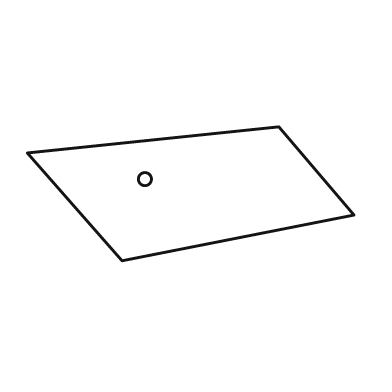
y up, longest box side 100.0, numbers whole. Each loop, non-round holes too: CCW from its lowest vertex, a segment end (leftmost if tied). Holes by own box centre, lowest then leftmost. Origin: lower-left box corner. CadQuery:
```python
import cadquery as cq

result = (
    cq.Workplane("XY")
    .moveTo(29.0, 0.0)
    .lineTo(100.0, 14.0)
    .lineTo(77.0, 41.0)
    .lineTo(0.0, 33.0)
    .close()
    .moveTo(36.0, 25.0)
    .circle(2.0)
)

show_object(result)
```